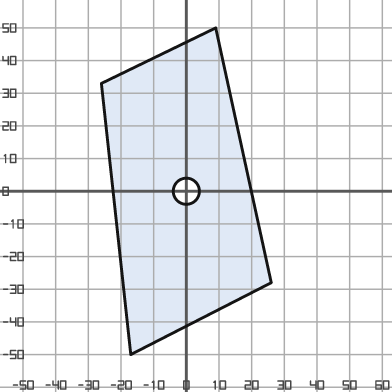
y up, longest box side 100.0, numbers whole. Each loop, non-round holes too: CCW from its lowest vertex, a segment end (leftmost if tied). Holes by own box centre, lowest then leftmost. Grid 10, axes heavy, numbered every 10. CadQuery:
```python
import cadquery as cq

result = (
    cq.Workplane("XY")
    .moveTo(-17.0, -50.0)
    .lineTo(26.0, -28.0)
    .lineTo(9.0, 50.0)
    .lineTo(-26.0, 33.0)
    .close()
    .moveTo(0.0, 0.0)
    .circle(4.0)
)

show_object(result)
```